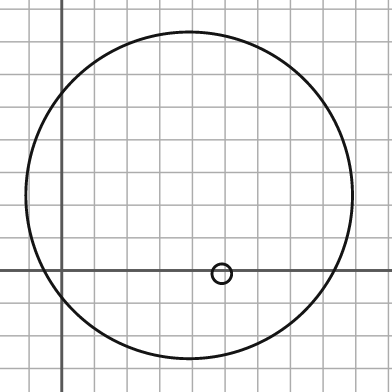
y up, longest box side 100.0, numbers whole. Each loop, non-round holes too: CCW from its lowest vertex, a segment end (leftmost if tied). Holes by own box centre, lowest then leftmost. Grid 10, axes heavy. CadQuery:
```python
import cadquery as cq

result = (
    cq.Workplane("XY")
    .moveTo(39.0, 23.0)
    .circle(50.0)
    .moveTo(49.0, -1.0)
    .circle(3.0)
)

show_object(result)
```